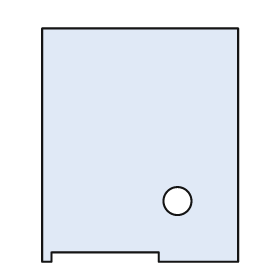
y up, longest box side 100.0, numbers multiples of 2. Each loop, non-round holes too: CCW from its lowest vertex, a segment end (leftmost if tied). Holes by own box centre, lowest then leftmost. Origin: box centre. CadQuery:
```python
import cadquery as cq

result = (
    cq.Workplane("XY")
    .moveTo(-42.0, -50.0)
    .lineTo(-38.0, -50.0)
    .lineTo(-38.0, -46.0)
    .lineTo(8.0, -46.0)
    .lineTo(8.0, -50.0)
    .lineTo(42.0, -50.0)
    .lineTo(42.0, 50.0)
    .lineTo(-42.0, 50.0)
    .close()
    .moveTo(16.0, -24.0)
    .circle(6.0)
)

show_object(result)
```